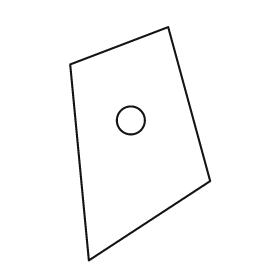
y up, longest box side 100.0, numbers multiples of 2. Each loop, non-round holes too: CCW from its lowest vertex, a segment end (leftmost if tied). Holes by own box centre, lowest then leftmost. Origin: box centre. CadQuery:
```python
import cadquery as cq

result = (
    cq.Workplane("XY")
    .moveTo(-22.0, -50.0)
    .lineTo(30.0, -16.0)
    .lineTo(12.0, 50.0)
    .lineTo(-30.0, 34.0)
    .close()
    .moveTo(-4.0, 10.0)
    .circle(6.0)
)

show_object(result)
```